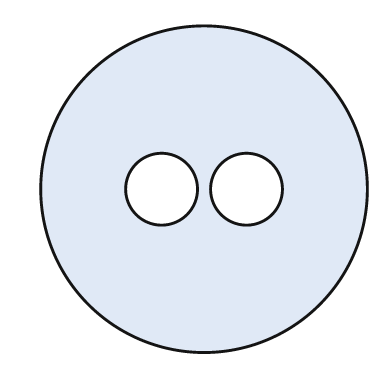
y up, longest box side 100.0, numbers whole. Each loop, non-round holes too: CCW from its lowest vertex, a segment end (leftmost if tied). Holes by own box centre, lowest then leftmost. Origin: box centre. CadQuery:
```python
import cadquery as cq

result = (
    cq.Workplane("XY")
    .moveTo(0.0, 0.0)
    .circle(50.0)
    .moveTo(-13.0, 0.0)
    .circle(11.0)
    .moveTo(13.0, 0.0)
    .circle(11.0)
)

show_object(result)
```